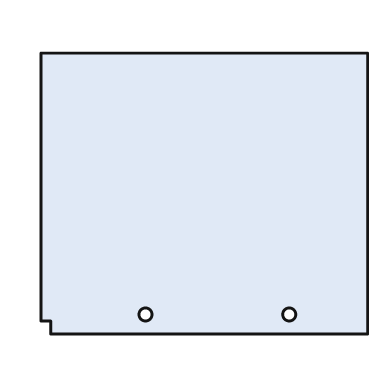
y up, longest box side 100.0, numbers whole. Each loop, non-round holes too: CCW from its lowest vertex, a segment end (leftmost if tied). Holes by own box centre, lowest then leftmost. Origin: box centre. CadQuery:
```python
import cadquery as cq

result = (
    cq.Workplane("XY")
    .moveTo(-47.0, -43.0)
    .lineTo(50.0, -43.0)
    .lineTo(50.0, 43.0)
    .lineTo(-50.0, 43.0)
    .lineTo(-50.0, -39.0)
    .lineTo(-47.0, -39.0)
    .close()
    .moveTo(-18.0, -37.0)
    .circle(2.0)
    .moveTo(26.0, -37.0)
    .circle(2.0)
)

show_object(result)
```